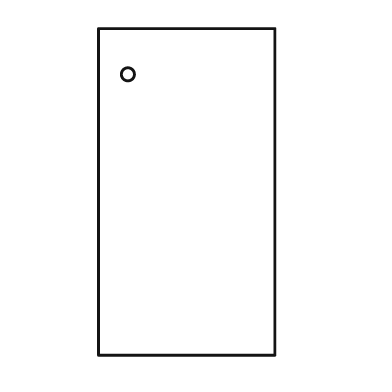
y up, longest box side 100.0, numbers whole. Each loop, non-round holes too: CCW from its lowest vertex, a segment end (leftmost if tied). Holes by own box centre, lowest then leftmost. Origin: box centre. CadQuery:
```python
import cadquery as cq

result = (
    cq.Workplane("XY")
    .moveTo(-27.0, -50.0)
    .lineTo(27.0, -50.0)
    .lineTo(27.0, 50.0)
    .lineTo(-27.0, 50.0)
    .close()
    .moveTo(-18.0, 36.0)
    .circle(2.0)
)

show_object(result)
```